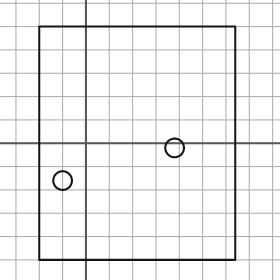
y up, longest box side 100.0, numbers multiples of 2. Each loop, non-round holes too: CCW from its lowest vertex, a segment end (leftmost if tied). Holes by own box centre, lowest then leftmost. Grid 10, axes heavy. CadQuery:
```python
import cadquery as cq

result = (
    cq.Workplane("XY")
    .moveTo(-20.0, -50.0)
    .lineTo(64.0, -50.0)
    .lineTo(64.0, 50.0)
    .lineTo(-20.0, 50.0)
    .close()
    .moveTo(-10.0, -16.0)
    .circle(4.0)
    .moveTo(38.0, -2.0)
    .circle(4.0)
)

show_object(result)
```